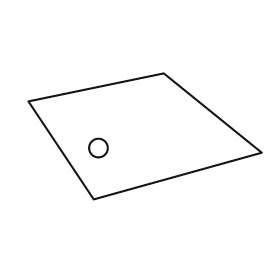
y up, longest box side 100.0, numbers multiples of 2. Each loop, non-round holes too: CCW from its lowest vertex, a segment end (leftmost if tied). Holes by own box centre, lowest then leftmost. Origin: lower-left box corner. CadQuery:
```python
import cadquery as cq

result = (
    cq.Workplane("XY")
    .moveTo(28.0, 0.0)
    .lineTo(100.0, 20.0)
    .lineTo(58.0, 54.0)
    .lineTo(0.0, 42.0)
    .close()
    .moveTo(30.0, 22.0)
    .circle(4.0)
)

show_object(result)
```